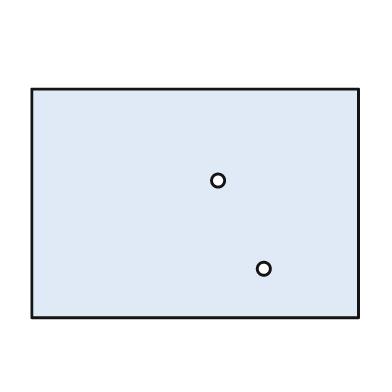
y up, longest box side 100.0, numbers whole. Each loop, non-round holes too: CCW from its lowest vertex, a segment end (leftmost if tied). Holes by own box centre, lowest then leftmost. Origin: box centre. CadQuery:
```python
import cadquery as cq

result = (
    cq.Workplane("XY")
    .moveTo(-50.0, -35.0)
    .lineTo(50.0, -35.0)
    .lineTo(50.0, 35.0)
    .lineTo(-50.0, 35.0)
    .close()
    .moveTo(21.0, -20.0)
    .circle(2.0)
    .moveTo(7.0, 7.0)
    .circle(2.0)
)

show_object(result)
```